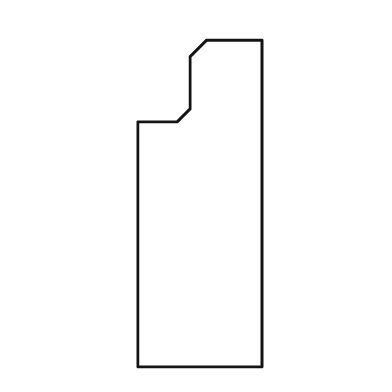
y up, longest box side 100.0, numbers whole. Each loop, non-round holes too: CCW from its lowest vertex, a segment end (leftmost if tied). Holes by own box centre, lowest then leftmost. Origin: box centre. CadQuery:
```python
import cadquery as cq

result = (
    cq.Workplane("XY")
    .moveTo(-19.0, -50.0)
    .lineTo(19.0, -50.0)
    .lineTo(19.0, 50.0)
    .lineTo(2.0, 50.0)
    .lineTo(-3.0, 45.0)
    .lineTo(-3.0, 29.0)
    .lineTo(-7.0, 25.0)
    .lineTo(-19.0, 25.0)
    .close()
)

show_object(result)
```